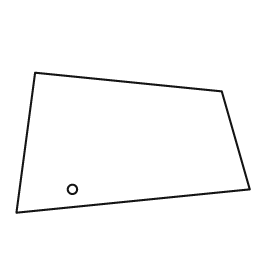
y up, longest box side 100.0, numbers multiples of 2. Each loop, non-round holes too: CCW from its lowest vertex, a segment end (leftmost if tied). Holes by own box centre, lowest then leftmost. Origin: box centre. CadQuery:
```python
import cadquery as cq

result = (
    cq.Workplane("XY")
    .moveTo(-50.0, -30.0)
    .lineTo(50.0, -20.0)
    .lineTo(38.0, 22.0)
    .lineTo(-42.0, 30.0)
    .close()
    .moveTo(-26.0, -20.0)
    .circle(2.0)
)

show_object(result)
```